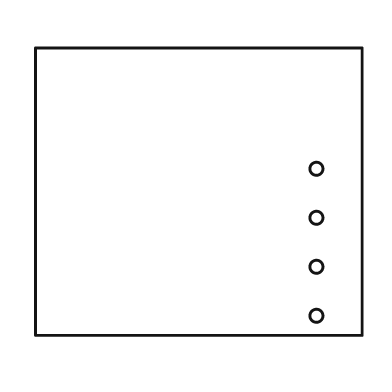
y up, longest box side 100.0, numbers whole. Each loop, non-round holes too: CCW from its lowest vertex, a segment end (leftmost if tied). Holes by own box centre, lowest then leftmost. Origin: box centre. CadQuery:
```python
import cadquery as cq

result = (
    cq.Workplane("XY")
    .moveTo(-50.0, -44.0)
    .lineTo(50.0, -44.0)
    .lineTo(50.0, 44.0)
    .lineTo(-50.0, 44.0)
    .close()
    .moveTo(36.0, -38.0)
    .circle(2.0)
    .moveTo(36.0, -23.0)
    .circle(2.0)
    .moveTo(36.0, -8.0)
    .circle(2.0)
    .moveTo(36.0, 7.0)
    .circle(2.0)
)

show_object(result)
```